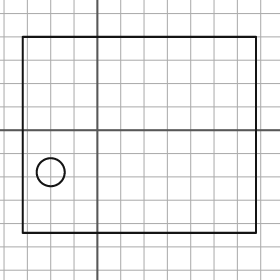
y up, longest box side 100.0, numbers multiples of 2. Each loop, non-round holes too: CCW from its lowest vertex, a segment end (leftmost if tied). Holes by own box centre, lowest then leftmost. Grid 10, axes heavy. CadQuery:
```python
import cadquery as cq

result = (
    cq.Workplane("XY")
    .moveTo(-32.0, -44.0)
    .lineTo(68.0, -44.0)
    .lineTo(68.0, 40.0)
    .lineTo(-32.0, 40.0)
    .close()
    .moveTo(-20.0, -18.0)
    .circle(6.0)
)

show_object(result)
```